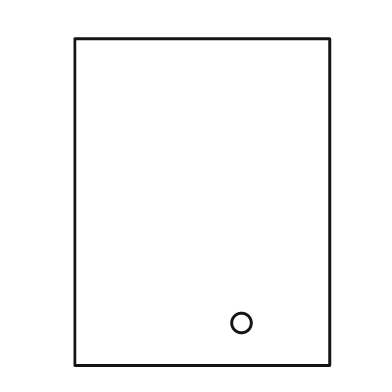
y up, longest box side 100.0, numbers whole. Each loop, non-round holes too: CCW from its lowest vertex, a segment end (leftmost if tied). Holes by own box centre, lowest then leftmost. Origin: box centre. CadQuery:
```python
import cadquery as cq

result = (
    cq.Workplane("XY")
    .moveTo(-39.0, -50.0)
    .lineTo(39.0, -50.0)
    .lineTo(39.0, 50.0)
    .lineTo(-39.0, 50.0)
    .close()
    .moveTo(12.0, -37.0)
    .circle(3.0)
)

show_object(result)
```